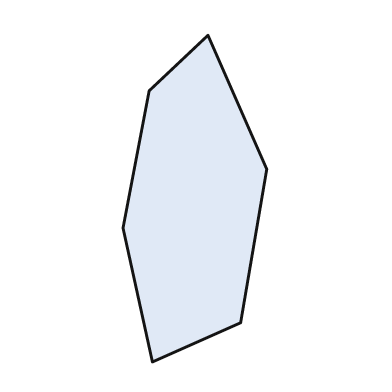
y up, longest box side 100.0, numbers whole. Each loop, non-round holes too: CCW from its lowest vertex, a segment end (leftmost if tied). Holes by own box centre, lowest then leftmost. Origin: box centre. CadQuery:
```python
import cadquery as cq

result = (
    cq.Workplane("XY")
    .moveTo(-13.0, -50.0)
    .lineTo(14.0, -38.0)
    .lineTo(22.0, 9.0)
    .lineTo(4.0, 50.0)
    .lineTo(-14.0, 33.0)
    .lineTo(-22.0, -9.0)
    .close()
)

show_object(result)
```